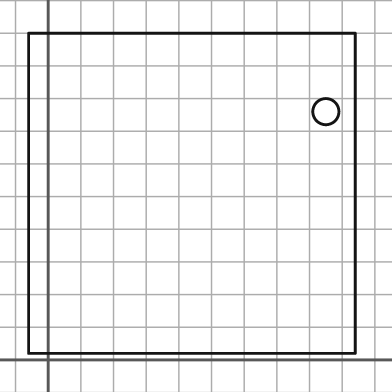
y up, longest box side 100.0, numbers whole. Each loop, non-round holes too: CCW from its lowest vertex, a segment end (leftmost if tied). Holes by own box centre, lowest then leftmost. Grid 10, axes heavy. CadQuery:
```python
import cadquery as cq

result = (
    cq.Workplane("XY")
    .moveTo(-6.0, 2.0)
    .lineTo(94.0, 2.0)
    .lineTo(94.0, 100.0)
    .lineTo(-6.0, 100.0)
    .close()
    .moveTo(85.0, 76.0)
    .circle(4.0)
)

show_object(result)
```